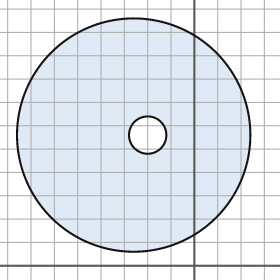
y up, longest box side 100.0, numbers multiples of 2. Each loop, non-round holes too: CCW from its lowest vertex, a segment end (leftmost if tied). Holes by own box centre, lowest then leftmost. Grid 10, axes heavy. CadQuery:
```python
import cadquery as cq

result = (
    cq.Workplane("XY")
    .moveTo(-26.0, 56.0)
    .circle(50.0)
    .moveTo(-20.0, 56.0)
    .circle(8.0)
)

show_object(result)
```